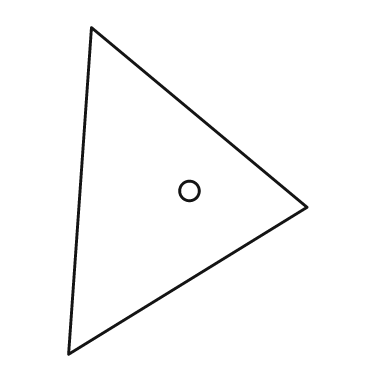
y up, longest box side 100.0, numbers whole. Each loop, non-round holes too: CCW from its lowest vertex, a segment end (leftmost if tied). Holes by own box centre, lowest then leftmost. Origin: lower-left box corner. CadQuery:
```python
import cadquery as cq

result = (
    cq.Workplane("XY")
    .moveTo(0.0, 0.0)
    .lineTo(73.0, 45.0)
    .lineTo(7.0, 100.0)
    .close()
    .moveTo(37.0, 50.0)
    .circle(3.0)
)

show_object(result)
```